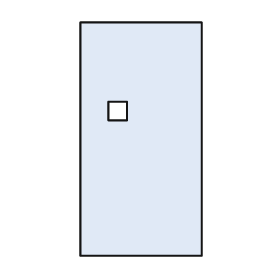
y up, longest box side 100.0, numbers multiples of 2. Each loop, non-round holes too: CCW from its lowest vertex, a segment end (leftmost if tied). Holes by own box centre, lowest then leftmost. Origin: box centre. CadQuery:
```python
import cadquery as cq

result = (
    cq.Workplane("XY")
    .moveTo(-26.0, -50.0)
    .lineTo(26.0, -50.0)
    .lineTo(26.0, 50.0)
    .lineTo(-26.0, 50.0)
    .close()
    .moveTo(-14.0, 8.0)
    .lineTo(-6.0, 8.0)
    .lineTo(-6.0, 16.0)
    .lineTo(-14.0, 16.0)
    .close()
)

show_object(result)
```